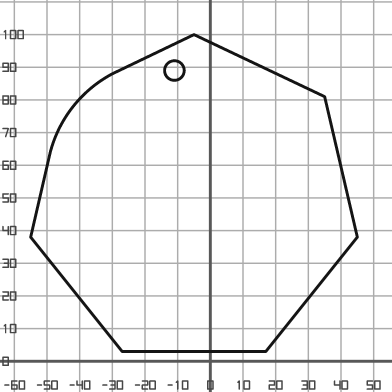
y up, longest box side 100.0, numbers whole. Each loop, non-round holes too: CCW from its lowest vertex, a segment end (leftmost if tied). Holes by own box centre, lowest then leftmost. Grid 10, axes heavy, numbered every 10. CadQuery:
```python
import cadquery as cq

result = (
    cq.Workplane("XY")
    .moveTo(-27.0, 3.0)
    .lineTo(17.0, 3.0)
    .lineTo(45.0, 38.0)
    .lineTo(35.0, 81.0)
    .lineTo(-5.0, 100.0)
    .lineTo(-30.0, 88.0)
    .threePointArc((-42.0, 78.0), (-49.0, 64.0))
    .lineTo(-55.0, 38.0)
    .close()
    .moveTo(-11.0, 89.0)
    .circle(3.0)
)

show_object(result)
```